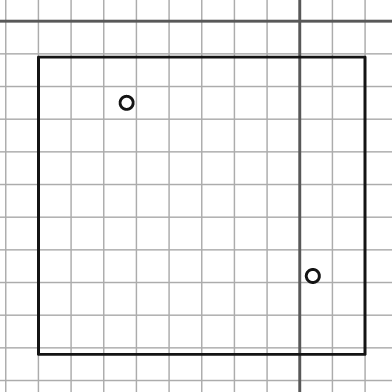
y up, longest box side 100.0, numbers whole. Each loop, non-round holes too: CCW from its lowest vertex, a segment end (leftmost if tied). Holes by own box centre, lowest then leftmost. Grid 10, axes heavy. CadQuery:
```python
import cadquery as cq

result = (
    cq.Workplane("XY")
    .moveTo(-80.0, -102.0)
    .lineTo(20.0, -102.0)
    .lineTo(20.0, -11.0)
    .lineTo(-80.0, -11.0)
    .close()
    .moveTo(4.0, -78.0)
    .circle(2.0)
    .moveTo(-53.0, -25.0)
    .circle(2.0)
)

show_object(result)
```